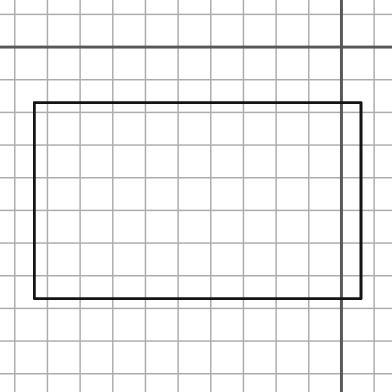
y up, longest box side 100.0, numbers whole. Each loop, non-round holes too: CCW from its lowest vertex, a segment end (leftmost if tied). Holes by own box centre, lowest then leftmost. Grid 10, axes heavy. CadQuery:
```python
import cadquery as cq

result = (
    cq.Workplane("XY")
    .moveTo(-94.0, -77.0)
    .lineTo(6.0, -77.0)
    .lineTo(6.0, -17.0)
    .lineTo(-94.0, -17.0)
    .close()
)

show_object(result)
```